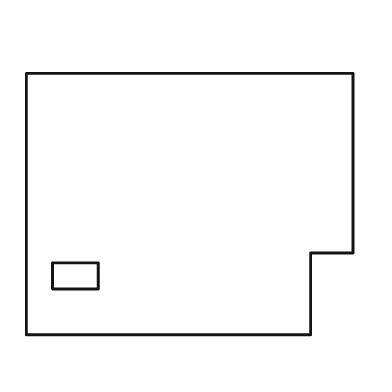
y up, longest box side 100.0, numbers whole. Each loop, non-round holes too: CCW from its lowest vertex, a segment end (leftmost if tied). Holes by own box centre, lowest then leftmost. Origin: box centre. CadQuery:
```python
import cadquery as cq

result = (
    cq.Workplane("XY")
    .moveTo(-50.0, -40.0)
    .lineTo(37.0, -40.0)
    .lineTo(37.0, -15.0)
    .lineTo(50.0, -15.0)
    .lineTo(50.0, 40.0)
    .lineTo(-50.0, 40.0)
    .close()
    .moveTo(-42.0, -26.0)
    .lineTo(-28.0, -26.0)
    .lineTo(-28.0, -18.0)
    .lineTo(-42.0, -18.0)
    .close()
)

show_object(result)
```